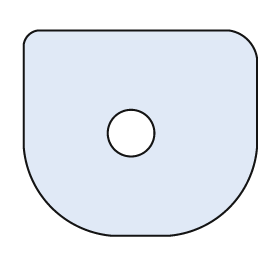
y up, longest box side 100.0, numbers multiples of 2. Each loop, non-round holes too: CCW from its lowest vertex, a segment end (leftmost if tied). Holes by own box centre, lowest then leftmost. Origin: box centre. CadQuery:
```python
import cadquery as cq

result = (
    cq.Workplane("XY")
    .moveTo(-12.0, -44.0)
    .lineTo(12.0, -44.0)
    .threePointArc((38.0, -32.0), (50.0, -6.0))
    .lineTo(50.0, 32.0)
    .threePointArc((46.0, 40.0), (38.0, 44.0))
    .lineTo(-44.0, 44.0)
    .threePointArc((-48.0, 42.0), (-50.0, 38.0))
    .lineTo(-50.0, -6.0)
    .threePointArc((-38.0, -32.0), (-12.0, -44.0))
    .close()
    .moveTo(-4.0, 0.0)
    .circle(10.0)
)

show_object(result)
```